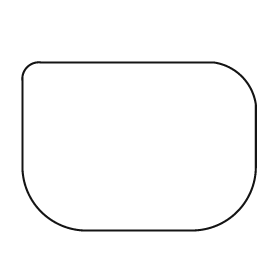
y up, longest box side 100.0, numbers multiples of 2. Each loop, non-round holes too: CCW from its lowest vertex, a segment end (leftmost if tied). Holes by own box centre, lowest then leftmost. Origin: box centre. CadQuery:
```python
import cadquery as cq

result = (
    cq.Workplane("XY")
    .moveTo(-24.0, -36.0)
    .lineTo(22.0, -36.0)
    .threePointArc((42.0, -28.0), (50.0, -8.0))
    .lineTo(50.0, 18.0)
    .threePointArc((44.0, 30.0), (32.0, 36.0))
    .lineTo(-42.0, 36.0)
    .threePointArc((-48.0, 34.0), (-50.0, 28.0))
    .lineTo(-50.0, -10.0)
    .threePointArc((-42.0, -28.0), (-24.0, -36.0))
    .close()
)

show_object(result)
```